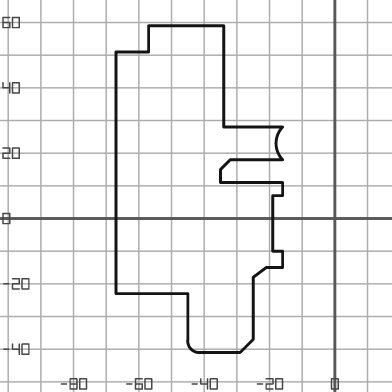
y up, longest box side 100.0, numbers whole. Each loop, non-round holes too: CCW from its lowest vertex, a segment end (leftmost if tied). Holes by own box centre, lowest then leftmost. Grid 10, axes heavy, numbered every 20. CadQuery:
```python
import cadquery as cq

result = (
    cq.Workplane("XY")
    .moveTo(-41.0, -41.0)
    .lineTo(-29.0, -41.0)
    .lineTo(-25.0, -37.0)
    .lineTo(-25.0, -18.0)
    .lineTo(-21.0, -15.0)
    .lineTo(-16.0, -15.0)
    .lineTo(-16.0, -10.0)
    .lineTo(-19.0, -10.0)
    .lineTo(-19.0, 7.0)
    .lineTo(-16.0, 7.0)
    .lineTo(-16.0, 11.0)
    .lineTo(-35.0, 11.0)
    .lineTo(-35.0, 15.0)
    .lineTo(-32.0, 18.0)
    .lineTo(-16.0, 18.0)
    .threePointArc((-18.0, 23.0), (-16.0, 28.0))
    .lineTo(-34.0, 28.0)
    .lineTo(-34.0, 59.0)
    .lineTo(-57.0, 59.0)
    .lineTo(-57.0, 51.0)
    .lineTo(-67.0, 51.0)
    .lineTo(-67.0, -23.0)
    .lineTo(-45.0, -23.0)
    .lineTo(-45.0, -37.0)
    .threePointArc((-44.0, -40.0), (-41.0, -41.0))
    .close()
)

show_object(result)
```